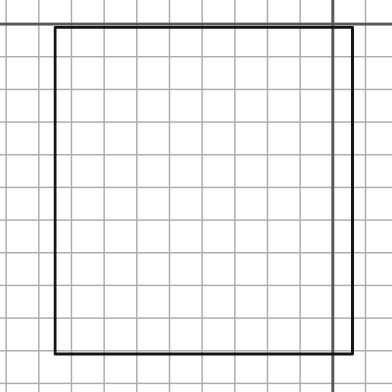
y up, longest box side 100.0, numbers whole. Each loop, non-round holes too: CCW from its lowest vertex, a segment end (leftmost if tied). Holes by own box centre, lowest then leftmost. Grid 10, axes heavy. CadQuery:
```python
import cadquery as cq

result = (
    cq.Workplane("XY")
    .moveTo(-85.0, -101.0)
    .lineTo(6.0, -101.0)
    .lineTo(6.0, -1.0)
    .lineTo(-85.0, -1.0)
    .close()
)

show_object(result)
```